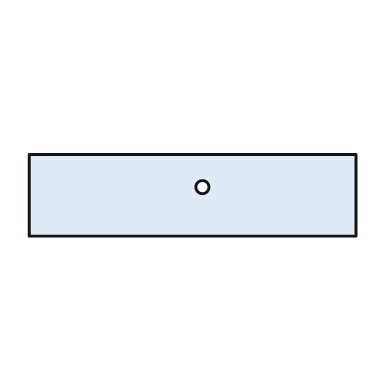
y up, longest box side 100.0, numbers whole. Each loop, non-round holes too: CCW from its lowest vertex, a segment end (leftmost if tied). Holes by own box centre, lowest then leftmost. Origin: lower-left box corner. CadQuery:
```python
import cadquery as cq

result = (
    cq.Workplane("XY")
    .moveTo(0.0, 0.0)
    .lineTo(100.0, 0.0)
    .lineTo(100.0, 25.0)
    .lineTo(0.0, 25.0)
    .close()
    .moveTo(53.0, 15.0)
    .circle(2.0)
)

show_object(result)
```